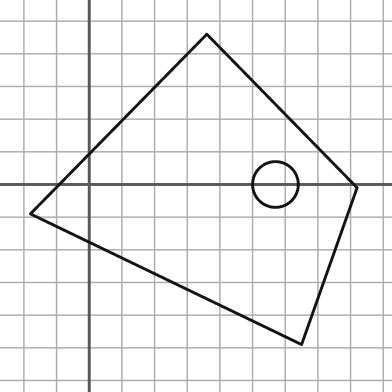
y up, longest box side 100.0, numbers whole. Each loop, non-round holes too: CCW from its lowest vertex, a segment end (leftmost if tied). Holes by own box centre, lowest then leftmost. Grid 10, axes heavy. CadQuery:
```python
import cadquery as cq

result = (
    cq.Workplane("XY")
    .moveTo(65.0, -49.0)
    .lineTo(82.0, -1.0)
    .lineTo(36.0, 46.0)
    .lineTo(-18.0, -9.0)
    .close()
    .moveTo(57.0, 0.0)
    .circle(7.0)
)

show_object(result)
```